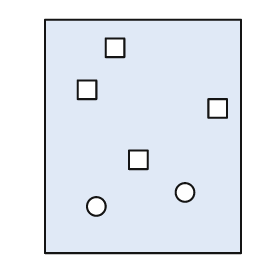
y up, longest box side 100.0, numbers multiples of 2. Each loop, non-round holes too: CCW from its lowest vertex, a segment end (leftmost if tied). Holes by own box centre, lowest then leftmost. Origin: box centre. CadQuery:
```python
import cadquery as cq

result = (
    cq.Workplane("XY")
    .moveTo(-42.0, -50.0)
    .lineTo(42.0, -50.0)
    .lineTo(42.0, 50.0)
    .lineTo(-42.0, 50.0)
    .close()
    .moveTo(-20.0, -30.0)
    .circle(4.0)
    .moveTo(18.0, -24.0)
    .circle(4.0)
    .moveTo(-6.0, -14.0)
    .lineTo(2.0, -14.0)
    .lineTo(2.0, -6.0)
    .lineTo(-6.0, -6.0)
    .close()
    .moveTo(28.0, 8.0)
    .lineTo(36.0, 8.0)
    .lineTo(36.0, 16.0)
    .lineTo(28.0, 16.0)
    .close()
    .moveTo(-28.0, 16.0)
    .lineTo(-20.0, 16.0)
    .lineTo(-20.0, 24.0)
    .lineTo(-28.0, 24.0)
    .close()
    .moveTo(-16.0, 34.0)
    .lineTo(-8.0, 34.0)
    .lineTo(-8.0, 42.0)
    .lineTo(-16.0, 42.0)
    .close()
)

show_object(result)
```